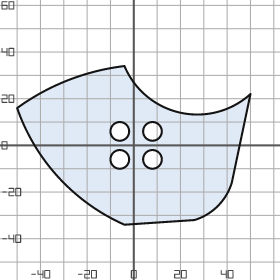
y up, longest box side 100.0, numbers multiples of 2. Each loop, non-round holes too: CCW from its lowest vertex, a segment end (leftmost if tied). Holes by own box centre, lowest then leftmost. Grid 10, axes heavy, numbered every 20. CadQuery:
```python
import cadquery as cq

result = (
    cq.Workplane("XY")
    .moveTo(-4.0, -34.0)
    .lineTo(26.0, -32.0)
    .threePointArc((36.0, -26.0), (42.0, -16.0))
    .lineTo(50.0, 22.0)
    .threePointArc((20.0, 14.0), (-4.0, 34.0))
    .threePointArc((-28.0, 28.0), (-50.0, 16.0))
    .threePointArc((-32.0, -14.0), (-4.0, -34.0))
    .close()
    .moveTo(-6.0, -6.0)
    .circle(4.0)
    .moveTo(8.0, -6.0)
    .circle(4.0)
    .moveTo(-6.0, 6.0)
    .circle(4.0)
    .moveTo(8.0, 6.0)
    .circle(4.0)
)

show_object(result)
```